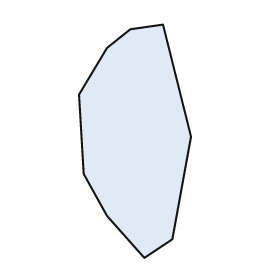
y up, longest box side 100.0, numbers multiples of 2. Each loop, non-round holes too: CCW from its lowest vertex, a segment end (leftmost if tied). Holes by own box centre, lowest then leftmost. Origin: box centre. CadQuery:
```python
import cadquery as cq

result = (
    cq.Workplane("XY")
    .moveTo(4.0, -50.0)
    .lineTo(16.0, -42.0)
    .lineTo(24.0, 2.0)
    .lineTo(12.0, 50.0)
    .lineTo(-2.0, 48.0)
    .lineTo(-12.0, 40.0)
    .lineTo(-24.0, 20.0)
    .lineTo(-22.0, -14.0)
    .lineTo(-12.0, -32.0)
    .close()
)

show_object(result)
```